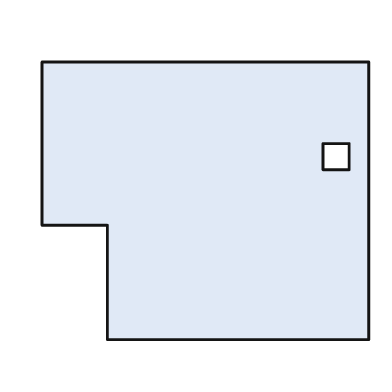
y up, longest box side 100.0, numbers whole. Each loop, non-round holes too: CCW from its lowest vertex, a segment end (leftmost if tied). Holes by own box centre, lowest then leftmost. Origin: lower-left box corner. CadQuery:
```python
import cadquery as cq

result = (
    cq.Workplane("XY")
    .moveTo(20.0, 0.0)
    .lineTo(100.0, 0.0)
    .lineTo(100.0, 85.0)
    .lineTo(0.0, 85.0)
    .lineTo(0.0, 35.0)
    .lineTo(20.0, 35.0)
    .close()
    .moveTo(86.0, 52.0)
    .lineTo(94.0, 52.0)
    .lineTo(94.0, 60.0)
    .lineTo(86.0, 60.0)
    .close()
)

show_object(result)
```